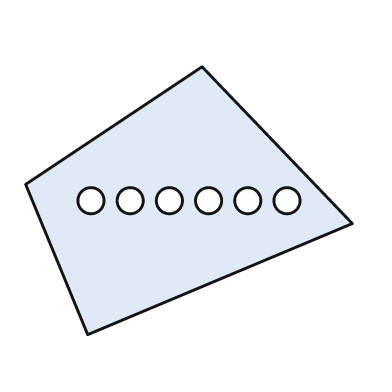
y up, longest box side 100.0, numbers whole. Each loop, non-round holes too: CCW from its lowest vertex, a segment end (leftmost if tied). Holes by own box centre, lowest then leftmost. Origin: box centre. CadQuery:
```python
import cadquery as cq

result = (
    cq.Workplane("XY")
    .moveTo(-31.0, -41.0)
    .lineTo(50.0, -7.0)
    .lineTo(4.0, 41.0)
    .lineTo(-50.0, 5.0)
    .close()
    .moveTo(-30.0, 0.0)
    .circle(4.0)
    .moveTo(-18.0, 0.0)
    .circle(4.0)
    .moveTo(-6.0, 0.0)
    .circle(4.0)
    .moveTo(6.0, 0.0)
    .circle(4.0)
    .moveTo(18.0, 0.0)
    .circle(4.0)
    .moveTo(30.0, 0.0)
    .circle(4.0)
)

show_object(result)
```